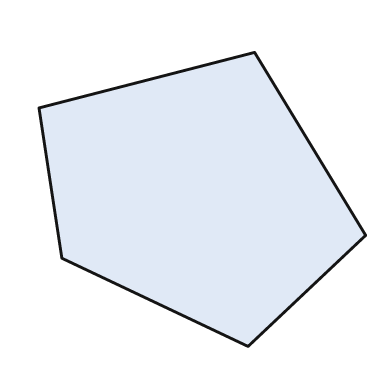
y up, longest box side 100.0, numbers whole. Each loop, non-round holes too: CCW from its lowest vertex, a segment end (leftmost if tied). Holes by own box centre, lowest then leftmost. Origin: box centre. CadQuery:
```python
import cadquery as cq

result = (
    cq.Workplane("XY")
    .moveTo(14.0, -45.0)
    .lineTo(50.0, -11.0)
    .lineTo(16.0, 45.0)
    .lineTo(-50.0, 28.0)
    .lineTo(-43.0, -18.0)
    .close()
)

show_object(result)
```